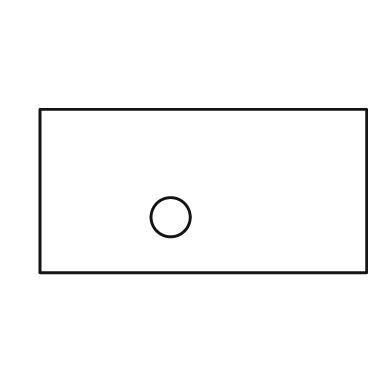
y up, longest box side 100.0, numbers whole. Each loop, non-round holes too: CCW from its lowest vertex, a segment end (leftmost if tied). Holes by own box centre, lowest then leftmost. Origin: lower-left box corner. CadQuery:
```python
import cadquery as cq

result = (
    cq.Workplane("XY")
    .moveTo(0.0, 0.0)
    .lineTo(100.0, 0.0)
    .lineTo(100.0, 50.0)
    .lineTo(0.0, 50.0)
    .close()
    .moveTo(40.0, 17.0)
    .circle(6.0)
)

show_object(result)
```